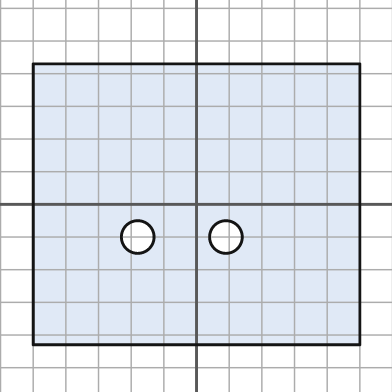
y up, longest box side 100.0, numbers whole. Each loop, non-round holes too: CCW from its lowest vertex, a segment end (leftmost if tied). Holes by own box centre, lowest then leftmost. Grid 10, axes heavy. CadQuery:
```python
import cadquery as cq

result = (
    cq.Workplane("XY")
    .moveTo(-50.0, -43.0)
    .lineTo(50.0, -43.0)
    .lineTo(50.0, 43.0)
    .lineTo(-50.0, 43.0)
    .close()
    .moveTo(-18.0, -10.0)
    .circle(5.0)
    .moveTo(9.0, -10.0)
    .circle(5.0)
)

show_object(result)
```